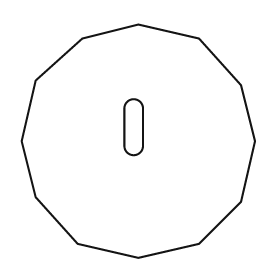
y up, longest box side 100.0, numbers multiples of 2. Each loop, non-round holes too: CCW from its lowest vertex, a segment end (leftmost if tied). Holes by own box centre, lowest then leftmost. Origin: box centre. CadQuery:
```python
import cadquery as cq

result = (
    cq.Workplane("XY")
    .moveTo(0.0, -50.0)
    .lineTo(26.0, -44.0)
    .lineTo(44.0, -26.0)
    .lineTo(50.0, 0.0)
    .lineTo(44.0, 24.0)
    .lineTo(26.0, 44.0)
    .lineTo(0.0, 50.0)
    .lineTo(-24.0, 44.0)
    .lineTo(-44.0, 26.0)
    .lineTo(-50.0, 0.0)
    .lineTo(-44.0, -24.0)
    .lineTo(-26.0, -44.0)
    .close()
    .moveTo(-6.0, -2.0)
    .threePointArc((-2.0, -6.0), (2.0, -2.0))
    .lineTo(2.0, 14.0)
    .threePointArc((-2.0, 18.0), (-6.0, 14.0))
    .close()
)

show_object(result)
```